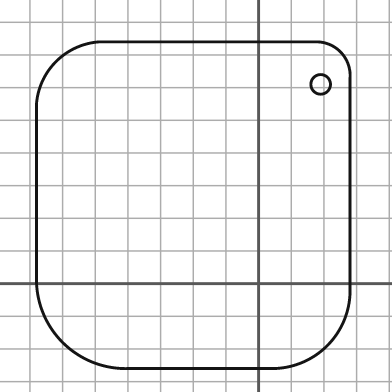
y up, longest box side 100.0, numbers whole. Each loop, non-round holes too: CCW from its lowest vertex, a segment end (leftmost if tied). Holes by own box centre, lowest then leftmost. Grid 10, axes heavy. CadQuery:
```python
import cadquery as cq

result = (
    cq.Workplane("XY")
    .moveTo(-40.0, -26.0)
    .lineTo(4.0, -26.0)
    .threePointArc((21.0, -19.0), (28.0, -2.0))
    .lineTo(28.0, 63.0)
    .threePointArc((25.0, 71.0), (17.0, 74.0))
    .lineTo(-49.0, 74.0)
    .threePointArc((-62.0, 68.0), (-68.0, 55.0))
    .lineTo(-68.0, 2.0)
    .threePointArc((-60.0, -18.0), (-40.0, -26.0))
    .close()
    .moveTo(19.0, 61.0)
    .circle(3.0)
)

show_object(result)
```